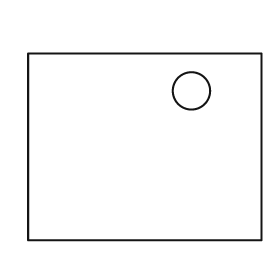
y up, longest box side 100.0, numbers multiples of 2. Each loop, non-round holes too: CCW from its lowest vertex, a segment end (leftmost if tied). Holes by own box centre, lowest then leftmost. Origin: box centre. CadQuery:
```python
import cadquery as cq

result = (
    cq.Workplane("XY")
    .moveTo(-50.0, -40.0)
    .lineTo(50.0, -40.0)
    .lineTo(50.0, 40.0)
    .lineTo(-50.0, 40.0)
    .close()
    .moveTo(20.0, 24.0)
    .circle(8.0)
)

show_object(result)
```